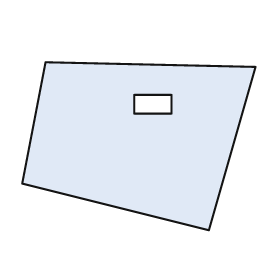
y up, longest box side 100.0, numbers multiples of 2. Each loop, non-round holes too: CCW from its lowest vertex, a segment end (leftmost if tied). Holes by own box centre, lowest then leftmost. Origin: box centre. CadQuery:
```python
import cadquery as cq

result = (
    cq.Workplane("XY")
    .moveTo(30.0, -36.0)
    .lineTo(50.0, 34.0)
    .lineTo(-40.0, 36.0)
    .lineTo(-50.0, -16.0)
    .close()
    .moveTo(-2.0, 14.0)
    .lineTo(14.0, 14.0)
    .lineTo(14.0, 22.0)
    .lineTo(-2.0, 22.0)
    .close()
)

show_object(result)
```